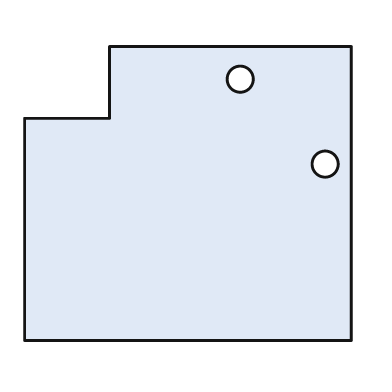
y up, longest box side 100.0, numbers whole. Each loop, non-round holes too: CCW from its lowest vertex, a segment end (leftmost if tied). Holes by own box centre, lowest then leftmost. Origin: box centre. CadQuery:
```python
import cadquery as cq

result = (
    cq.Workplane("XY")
    .moveTo(-50.0, -45.0)
    .lineTo(50.0, -45.0)
    .lineTo(50.0, 45.0)
    .lineTo(-24.0, 45.0)
    .lineTo(-24.0, 23.0)
    .lineTo(-50.0, 23.0)
    .close()
    .moveTo(42.0, 9.0)
    .circle(4.0)
    .moveTo(16.0, 35.0)
    .circle(4.0)
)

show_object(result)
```